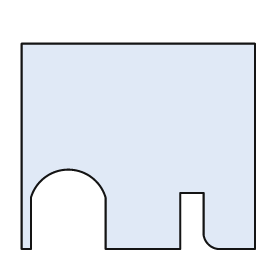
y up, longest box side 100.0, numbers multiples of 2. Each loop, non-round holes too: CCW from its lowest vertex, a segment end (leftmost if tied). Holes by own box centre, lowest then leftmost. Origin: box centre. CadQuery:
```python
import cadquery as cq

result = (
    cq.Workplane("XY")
    .moveTo(-50.0, -44.0)
    .lineTo(-46.0, -44.0)
    .lineTo(-46.0, -22.0)
    .threePointArc((-30.0, -10.0), (-14.0, -22.0))
    .lineTo(-14.0, -44.0)
    .lineTo(18.0, -44.0)
    .lineTo(18.0, -20.0)
    .lineTo(28.0, -20.0)
    .lineTo(28.0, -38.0)
    .threePointArc((30.0, -42.0), (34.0, -44.0))
    .lineTo(50.0, -44.0)
    .lineTo(50.0, 44.0)
    .lineTo(-50.0, 44.0)
    .close()
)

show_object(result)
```